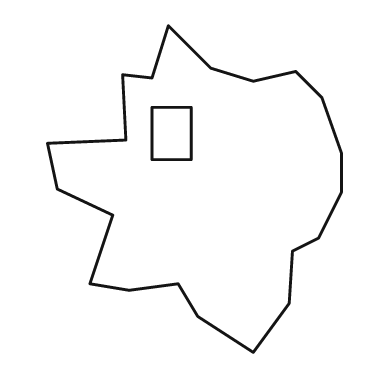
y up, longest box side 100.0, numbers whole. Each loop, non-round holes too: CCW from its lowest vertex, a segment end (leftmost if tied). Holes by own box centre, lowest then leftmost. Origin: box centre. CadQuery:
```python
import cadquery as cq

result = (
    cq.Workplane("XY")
    .moveTo(18.0, -50.0)
    .lineTo(29.0, -35.0)
    .lineTo(30.0, -19.0)
    .lineTo(38.0, -15.0)
    .lineTo(45.0, -1.0)
    .lineTo(45.0, 11.0)
    .lineTo(39.0, 28.0)
    .lineTo(31.0, 36.0)
    .lineTo(18.0, 33.0)
    .lineTo(5.0, 37.0)
    .lineTo(-8.0, 50.0)
    .lineTo(-13.0, 34.0)
    .lineTo(-22.0, 35.0)
    .lineTo(-21.0, 15.0)
    .lineTo(-45.0, 14.0)
    .lineTo(-42.0, 0.0)
    .lineTo(-25.0, -8.0)
    .lineTo(-32.0, -29.0)
    .lineTo(-20.0, -31.0)
    .lineTo(-5.0, -29.0)
    .lineTo(1.0, -39.0)
    .close()
    .moveTo(-13.0, 9.0)
    .lineTo(-1.0, 9.0)
    .lineTo(-1.0, 25.0)
    .lineTo(-13.0, 25.0)
    .close()
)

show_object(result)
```